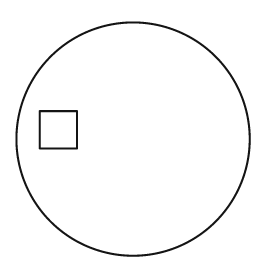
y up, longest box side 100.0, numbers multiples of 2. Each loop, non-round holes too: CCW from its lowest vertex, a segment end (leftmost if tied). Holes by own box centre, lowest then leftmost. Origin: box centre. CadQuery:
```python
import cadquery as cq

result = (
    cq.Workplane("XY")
    .moveTo(0.0, 0.0)
    .circle(50.0)
    .moveTo(-40.0, -4.0)
    .lineTo(-24.0, -4.0)
    .lineTo(-24.0, 12.0)
    .lineTo(-40.0, 12.0)
    .close()
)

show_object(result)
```